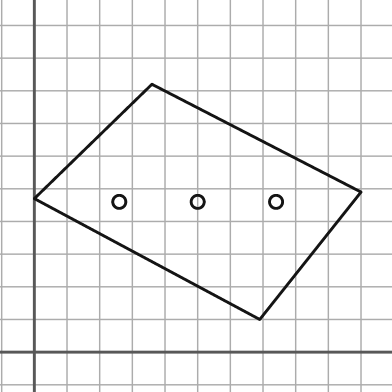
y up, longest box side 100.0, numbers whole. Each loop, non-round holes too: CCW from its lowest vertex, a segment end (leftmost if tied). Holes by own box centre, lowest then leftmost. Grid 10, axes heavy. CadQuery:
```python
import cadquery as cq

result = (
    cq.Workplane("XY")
    .moveTo(69.0, 10.0)
    .lineTo(100.0, 49.0)
    .lineTo(36.0, 82.0)
    .lineTo(0.0, 47.0)
    .close()
    .moveTo(26.0, 46.0)
    .circle(2.0)
    .moveTo(50.0, 46.0)
    .circle(2.0)
    .moveTo(74.0, 46.0)
    .circle(2.0)
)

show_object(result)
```